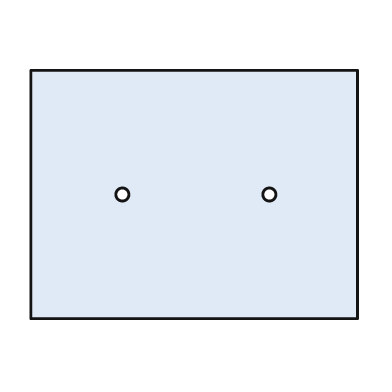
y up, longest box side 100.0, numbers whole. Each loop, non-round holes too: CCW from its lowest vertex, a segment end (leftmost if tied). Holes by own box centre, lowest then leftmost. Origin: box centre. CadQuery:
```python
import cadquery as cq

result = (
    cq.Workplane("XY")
    .moveTo(-50.0, -38.0)
    .lineTo(50.0, -38.0)
    .lineTo(50.0, 38.0)
    .lineTo(-50.0, 38.0)
    .close()
    .moveTo(-22.0, 0.0)
    .circle(2.0)
    .moveTo(23.0, 0.0)
    .circle(2.0)
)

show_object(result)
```